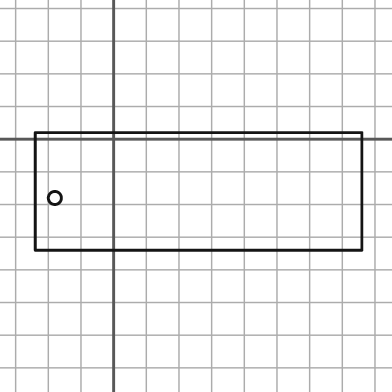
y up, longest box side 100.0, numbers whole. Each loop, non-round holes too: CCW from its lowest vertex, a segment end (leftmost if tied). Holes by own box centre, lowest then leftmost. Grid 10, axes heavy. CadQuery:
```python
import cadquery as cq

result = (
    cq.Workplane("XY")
    .moveTo(-24.0, -34.0)
    .lineTo(76.0, -34.0)
    .lineTo(76.0, 2.0)
    .lineTo(-24.0, 2.0)
    .close()
    .moveTo(-18.0, -18.0)
    .circle(2.0)
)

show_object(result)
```